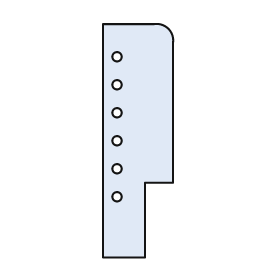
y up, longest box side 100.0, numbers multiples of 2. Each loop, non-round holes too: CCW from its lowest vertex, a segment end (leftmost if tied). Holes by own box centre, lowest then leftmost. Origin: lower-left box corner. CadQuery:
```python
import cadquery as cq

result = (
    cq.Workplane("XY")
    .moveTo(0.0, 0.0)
    .lineTo(18.0, 0.0)
    .lineTo(18.0, 32.0)
    .lineTo(30.0, 32.0)
    .lineTo(30.0, 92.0)
    .threePointArc((28.0, 98.0), (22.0, 100.0))
    .lineTo(0.0, 100.0)
    .close()
    .moveTo(6.0, 26.0)
    .circle(2.0)
    .moveTo(6.0, 38.0)
    .circle(2.0)
    .moveTo(6.0, 50.0)
    .circle(2.0)
    .moveTo(6.0, 62.0)
    .circle(2.0)
    .moveTo(6.0, 74.0)
    .circle(2.0)
    .moveTo(6.0, 86.0)
    .circle(2.0)
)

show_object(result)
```